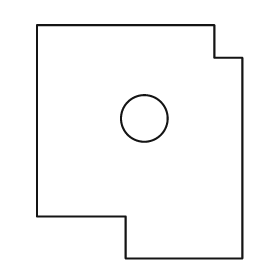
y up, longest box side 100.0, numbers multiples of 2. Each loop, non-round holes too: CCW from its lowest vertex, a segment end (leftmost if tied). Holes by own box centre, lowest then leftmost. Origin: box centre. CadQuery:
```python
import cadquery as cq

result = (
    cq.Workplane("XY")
    .moveTo(-6.0, -50.0)
    .lineTo(44.0, -50.0)
    .lineTo(44.0, 36.0)
    .lineTo(32.0, 36.0)
    .lineTo(32.0, 50.0)
    .lineTo(-44.0, 50.0)
    .lineTo(-44.0, -32.0)
    .lineTo(-6.0, -32.0)
    .close()
    .moveTo(2.0, 10.0)
    .circle(10.0)
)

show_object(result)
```